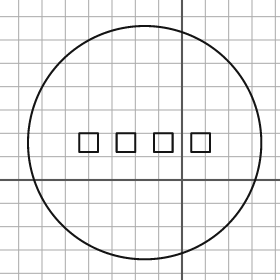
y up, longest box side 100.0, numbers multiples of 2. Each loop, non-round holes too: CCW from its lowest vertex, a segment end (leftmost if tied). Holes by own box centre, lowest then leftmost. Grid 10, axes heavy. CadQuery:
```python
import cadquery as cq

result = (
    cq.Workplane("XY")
    .moveTo(-16.0, 16.0)
    .circle(50.0)
    .moveTo(-44.0, 12.0)
    .lineTo(-36.0, 12.0)
    .lineTo(-36.0, 20.0)
    .lineTo(-44.0, 20.0)
    .close()
    .moveTo(-28.0, 12.0)
    .lineTo(-20.0, 12.0)
    .lineTo(-20.0, 20.0)
    .lineTo(-28.0, 20.0)
    .close()
    .moveTo(-12.0, 12.0)
    .lineTo(-4.0, 12.0)
    .lineTo(-4.0, 20.0)
    .lineTo(-12.0, 20.0)
    .close()
    .moveTo(4.0, 12.0)
    .lineTo(12.0, 12.0)
    .lineTo(12.0, 20.0)
    .lineTo(4.0, 20.0)
    .close()
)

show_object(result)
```